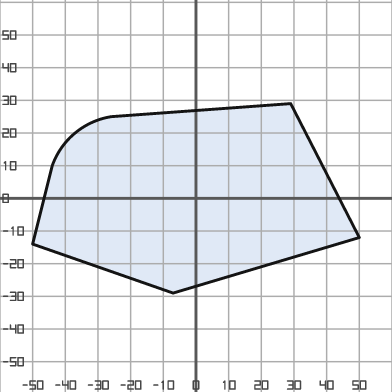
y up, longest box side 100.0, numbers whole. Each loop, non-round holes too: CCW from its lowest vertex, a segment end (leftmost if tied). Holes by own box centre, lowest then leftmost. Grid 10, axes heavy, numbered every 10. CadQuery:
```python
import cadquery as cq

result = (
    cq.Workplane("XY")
    .moveTo(-7.0, -29.0)
    .lineTo(50.0, -12.0)
    .lineTo(29.0, 29.0)
    .lineTo(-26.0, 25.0)
    .threePointArc((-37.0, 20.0), (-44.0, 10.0))
    .lineTo(-50.0, -14.0)
    .close()
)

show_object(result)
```